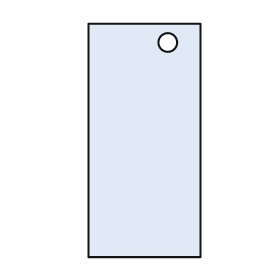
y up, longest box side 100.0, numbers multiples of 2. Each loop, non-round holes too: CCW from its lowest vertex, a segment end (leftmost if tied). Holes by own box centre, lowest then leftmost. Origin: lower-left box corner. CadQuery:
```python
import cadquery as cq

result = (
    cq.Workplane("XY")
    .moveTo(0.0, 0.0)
    .lineTo(48.0, 0.0)
    .lineTo(48.0, 100.0)
    .lineTo(0.0, 100.0)
    .close()
    .moveTo(34.0, 92.0)
    .circle(4.0)
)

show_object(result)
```